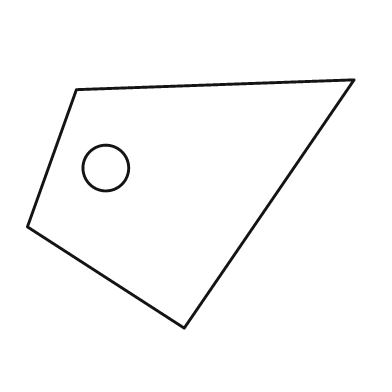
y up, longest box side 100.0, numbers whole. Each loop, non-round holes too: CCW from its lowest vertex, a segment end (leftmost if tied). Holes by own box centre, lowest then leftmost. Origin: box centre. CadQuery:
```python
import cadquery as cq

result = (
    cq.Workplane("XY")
    .moveTo(-2.0, -38.0)
    .lineTo(50.0, 38.0)
    .lineTo(-35.0, 35.0)
    .lineTo(-50.0, -7.0)
    .close()
    .moveTo(-26.0, 11.0)
    .circle(7.0)
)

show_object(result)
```